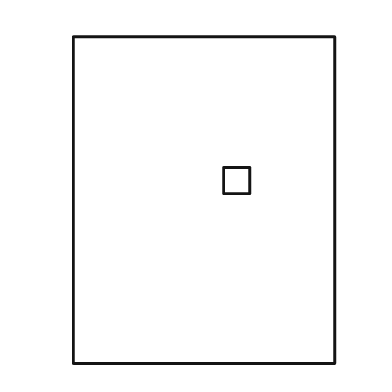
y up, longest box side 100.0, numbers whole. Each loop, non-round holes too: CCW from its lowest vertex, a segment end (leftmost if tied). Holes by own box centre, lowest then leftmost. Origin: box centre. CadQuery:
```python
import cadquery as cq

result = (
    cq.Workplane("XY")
    .moveTo(-40.0, -50.0)
    .lineTo(40.0, -50.0)
    .lineTo(40.0, 50.0)
    .lineTo(-40.0, 50.0)
    .close()
    .moveTo(6.0, 2.0)
    .lineTo(14.0, 2.0)
    .lineTo(14.0, 10.0)
    .lineTo(6.0, 10.0)
    .close()
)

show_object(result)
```